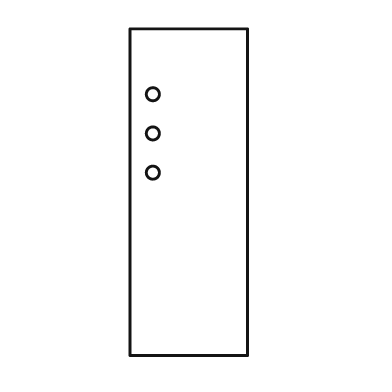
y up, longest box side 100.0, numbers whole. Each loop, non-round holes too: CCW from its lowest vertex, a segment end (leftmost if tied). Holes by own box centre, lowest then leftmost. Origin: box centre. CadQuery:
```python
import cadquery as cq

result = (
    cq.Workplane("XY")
    .moveTo(-18.0, -50.0)
    .lineTo(18.0, -50.0)
    .lineTo(18.0, 50.0)
    .lineTo(-18.0, 50.0)
    .close()
    .moveTo(-11.0, 6.0)
    .circle(2.0)
    .moveTo(-11.0, 18.0)
    .circle(2.0)
    .moveTo(-11.0, 30.0)
    .circle(2.0)
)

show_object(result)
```